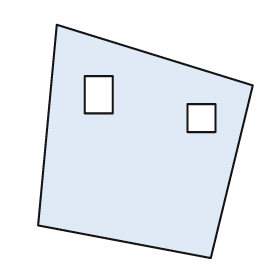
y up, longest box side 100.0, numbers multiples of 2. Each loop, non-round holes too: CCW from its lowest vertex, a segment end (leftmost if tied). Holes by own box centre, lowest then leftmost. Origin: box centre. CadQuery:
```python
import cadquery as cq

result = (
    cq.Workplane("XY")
    .moveTo(28.0, -50.0)
    .lineTo(46.0, 24.0)
    .lineTo(-38.0, 50.0)
    .lineTo(-46.0, -36.0)
    .close()
    .moveTo(18.0, 4.0)
    .lineTo(30.0, 4.0)
    .lineTo(30.0, 16.0)
    .lineTo(18.0, 16.0)
    .close()
    .moveTo(-26.0, 12.0)
    .lineTo(-14.0, 12.0)
    .lineTo(-14.0, 28.0)
    .lineTo(-26.0, 28.0)
    .close()
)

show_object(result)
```